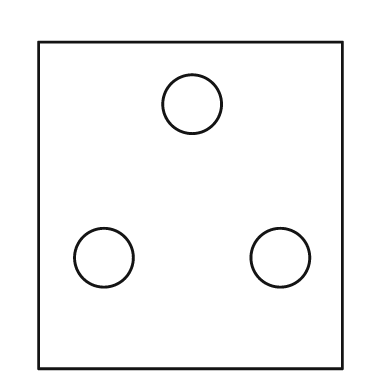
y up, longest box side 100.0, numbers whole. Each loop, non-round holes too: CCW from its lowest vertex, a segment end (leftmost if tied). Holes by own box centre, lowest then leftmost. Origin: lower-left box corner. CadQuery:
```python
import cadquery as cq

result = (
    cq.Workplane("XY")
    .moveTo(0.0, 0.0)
    .lineTo(93.0, 0.0)
    .lineTo(93.0, 100.0)
    .lineTo(0.0, 100.0)
    .close()
    .moveTo(20.0, 34.0)
    .circle(9.0)
    .moveTo(74.0, 34.0)
    .circle(9.0)
    .moveTo(47.0, 81.0)
    .circle(9.0)
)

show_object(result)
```